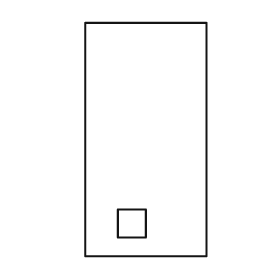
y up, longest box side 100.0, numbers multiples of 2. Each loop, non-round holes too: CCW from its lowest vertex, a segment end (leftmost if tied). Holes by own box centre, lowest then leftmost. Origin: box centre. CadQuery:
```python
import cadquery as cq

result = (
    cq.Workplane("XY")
    .moveTo(-26.0, -50.0)
    .lineTo(26.0, -50.0)
    .lineTo(26.0, 50.0)
    .lineTo(-26.0, 50.0)
    .close()
    .moveTo(-12.0, -42.0)
    .lineTo(0.0, -42.0)
    .lineTo(0.0, -30.0)
    .lineTo(-12.0, -30.0)
    .close()
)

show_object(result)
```